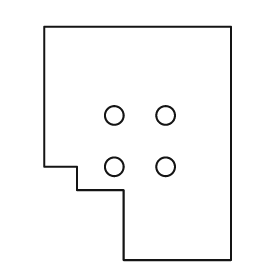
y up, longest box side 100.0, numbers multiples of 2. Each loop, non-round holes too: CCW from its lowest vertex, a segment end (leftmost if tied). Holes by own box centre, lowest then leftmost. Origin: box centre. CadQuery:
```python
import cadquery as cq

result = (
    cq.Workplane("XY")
    .moveTo(-6.0, -50.0)
    .lineTo(40.0, -50.0)
    .lineTo(40.0, 50.0)
    .lineTo(-40.0, 50.0)
    .lineTo(-40.0, -10.0)
    .lineTo(-26.0, -10.0)
    .lineTo(-26.0, -20.0)
    .lineTo(-6.0, -20.0)
    .close()
    .moveTo(-10.0, -10.0)
    .circle(4.0)
    .moveTo(12.0, -10.0)
    .circle(4.0)
    .moveTo(-10.0, 12.0)
    .circle(4.0)
    .moveTo(12.0, 12.0)
    .circle(4.0)
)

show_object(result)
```